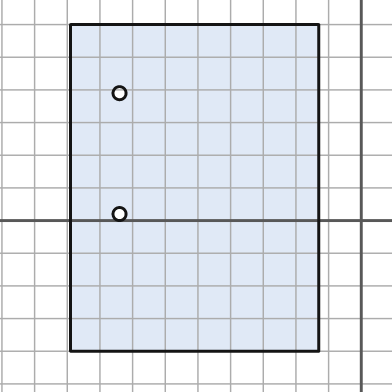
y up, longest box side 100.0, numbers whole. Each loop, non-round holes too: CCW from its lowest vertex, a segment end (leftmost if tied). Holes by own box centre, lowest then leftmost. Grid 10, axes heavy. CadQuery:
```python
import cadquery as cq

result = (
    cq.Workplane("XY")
    .moveTo(-89.0, -40.0)
    .lineTo(-13.0, -40.0)
    .lineTo(-13.0, 60.0)
    .lineTo(-89.0, 60.0)
    .close()
    .moveTo(-74.0, 2.0)
    .circle(2.0)
    .moveTo(-74.0, 39.0)
    .circle(2.0)
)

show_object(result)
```